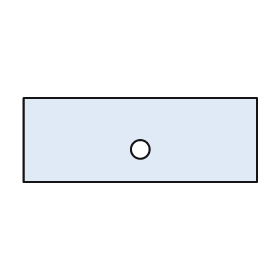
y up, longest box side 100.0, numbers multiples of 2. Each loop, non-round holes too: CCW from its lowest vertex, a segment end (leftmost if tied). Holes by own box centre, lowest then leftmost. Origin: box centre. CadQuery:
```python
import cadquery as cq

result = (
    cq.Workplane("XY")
    .moveTo(-50.0, -18.0)
    .lineTo(50.0, -18.0)
    .lineTo(50.0, 18.0)
    .lineTo(-50.0, 18.0)
    .close()
    .moveTo(0.0, -4.0)
    .circle(4.0)
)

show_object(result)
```